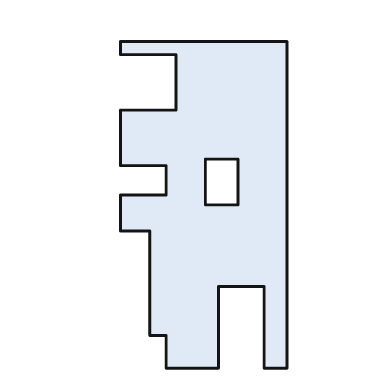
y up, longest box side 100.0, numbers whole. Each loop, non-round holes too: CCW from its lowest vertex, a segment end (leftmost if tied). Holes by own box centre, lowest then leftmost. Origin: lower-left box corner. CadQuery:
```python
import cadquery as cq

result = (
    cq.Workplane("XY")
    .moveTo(14.0, 0.0)
    .lineTo(30.0, 0.0)
    .lineTo(30.0, 25.0)
    .lineTo(44.0, 25.0)
    .lineTo(44.0, 0.0)
    .lineTo(51.0, 0.0)
    .lineTo(51.0, 100.0)
    .lineTo(0.0, 100.0)
    .lineTo(0.0, 96.0)
    .lineTo(17.0, 96.0)
    .lineTo(17.0, 79.0)
    .lineTo(0.0, 79.0)
    .lineTo(0.0, 62.0)
    .lineTo(14.0, 62.0)
    .lineTo(14.0, 53.0)
    .lineTo(0.0, 53.0)
    .lineTo(0.0, 42.0)
    .lineTo(9.0, 42.0)
    .lineTo(9.0, 10.0)
    .lineTo(14.0, 10.0)
    .close()
    .moveTo(26.0, 50.0)
    .lineTo(36.0, 50.0)
    .lineTo(36.0, 64.0)
    .lineTo(26.0, 64.0)
    .close()
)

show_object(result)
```